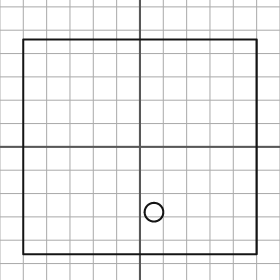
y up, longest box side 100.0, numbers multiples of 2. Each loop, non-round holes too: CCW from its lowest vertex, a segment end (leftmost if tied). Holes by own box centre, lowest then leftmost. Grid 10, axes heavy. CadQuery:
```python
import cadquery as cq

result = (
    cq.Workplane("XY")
    .moveTo(-50.0, -46.0)
    .lineTo(50.0, -46.0)
    .lineTo(50.0, 46.0)
    .lineTo(-50.0, 46.0)
    .close()
    .moveTo(6.0, -28.0)
    .circle(4.0)
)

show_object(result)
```